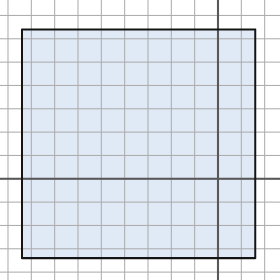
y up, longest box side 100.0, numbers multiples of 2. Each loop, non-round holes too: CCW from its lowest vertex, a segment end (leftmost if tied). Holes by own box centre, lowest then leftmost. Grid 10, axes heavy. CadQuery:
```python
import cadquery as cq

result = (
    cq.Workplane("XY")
    .moveTo(-84.0, -34.0)
    .lineTo(16.0, -34.0)
    .lineTo(16.0, 64.0)
    .lineTo(-84.0, 64.0)
    .close()
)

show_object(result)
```